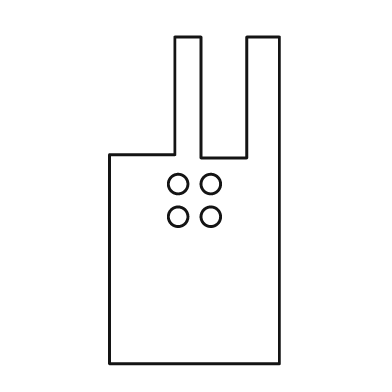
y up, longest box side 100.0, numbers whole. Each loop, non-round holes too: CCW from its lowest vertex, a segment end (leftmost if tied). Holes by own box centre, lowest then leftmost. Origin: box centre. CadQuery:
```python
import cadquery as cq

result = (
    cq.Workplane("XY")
    .moveTo(-26.0, -50.0)
    .lineTo(26.0, -50.0)
    .lineTo(26.0, 50.0)
    .lineTo(16.0, 50.0)
    .lineTo(16.0, 13.0)
    .lineTo(2.0, 13.0)
    .lineTo(2.0, 50.0)
    .lineTo(-6.0, 50.0)
    .lineTo(-6.0, 14.0)
    .lineTo(-26.0, 14.0)
    .close()
    .moveTo(-5.0, -5.0)
    .circle(3.0)
    .moveTo(5.0, -5.0)
    .circle(3.0)
    .moveTo(-5.0, 5.0)
    .circle(3.0)
    .moveTo(5.0, 5.0)
    .circle(3.0)
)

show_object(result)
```